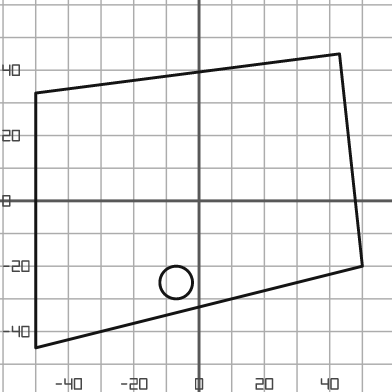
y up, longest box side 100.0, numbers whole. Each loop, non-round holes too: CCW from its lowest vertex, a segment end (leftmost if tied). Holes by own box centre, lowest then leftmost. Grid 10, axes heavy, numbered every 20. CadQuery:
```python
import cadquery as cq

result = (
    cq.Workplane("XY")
    .moveTo(-50.0, -45.0)
    .lineTo(50.0, -20.0)
    .lineTo(43.0, 45.0)
    .lineTo(-50.0, 33.0)
    .close()
    .moveTo(-7.0, -25.0)
    .circle(5.0)
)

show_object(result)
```